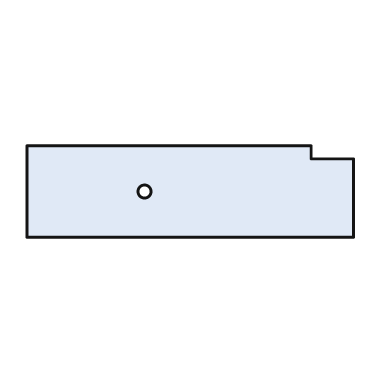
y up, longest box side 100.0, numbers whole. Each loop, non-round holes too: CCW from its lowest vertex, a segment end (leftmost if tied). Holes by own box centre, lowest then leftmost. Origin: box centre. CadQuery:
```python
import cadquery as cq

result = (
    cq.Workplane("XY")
    .moveTo(-50.0, -14.0)
    .lineTo(50.0, -14.0)
    .lineTo(50.0, 10.0)
    .lineTo(37.0, 10.0)
    .lineTo(37.0, 14.0)
    .lineTo(-50.0, 14.0)
    .close()
    .moveTo(-14.0, 0.0)
    .circle(2.0)
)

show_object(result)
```